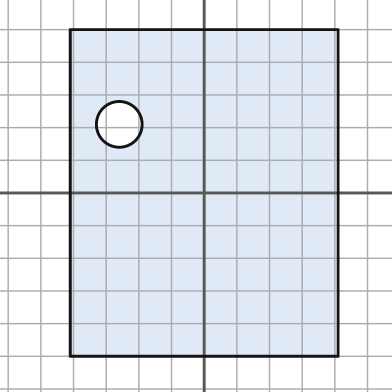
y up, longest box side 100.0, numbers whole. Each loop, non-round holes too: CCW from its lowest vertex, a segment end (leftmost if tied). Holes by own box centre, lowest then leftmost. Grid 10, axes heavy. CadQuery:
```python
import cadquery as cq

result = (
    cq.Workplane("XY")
    .moveTo(-41.0, -50.0)
    .lineTo(41.0, -50.0)
    .lineTo(41.0, 50.0)
    .lineTo(-41.0, 50.0)
    .close()
    .moveTo(-26.0, 21.0)
    .circle(7.0)
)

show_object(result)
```